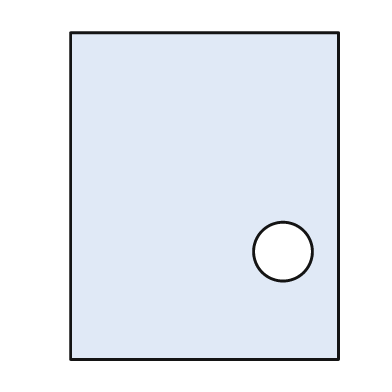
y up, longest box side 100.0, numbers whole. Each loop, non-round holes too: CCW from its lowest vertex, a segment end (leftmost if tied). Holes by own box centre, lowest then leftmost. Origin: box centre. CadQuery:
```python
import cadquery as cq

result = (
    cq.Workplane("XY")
    .moveTo(-41.0, -50.0)
    .lineTo(41.0, -50.0)
    .lineTo(41.0, 50.0)
    .lineTo(-41.0, 50.0)
    .close()
    .moveTo(24.0, -17.0)
    .circle(9.0)
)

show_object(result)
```